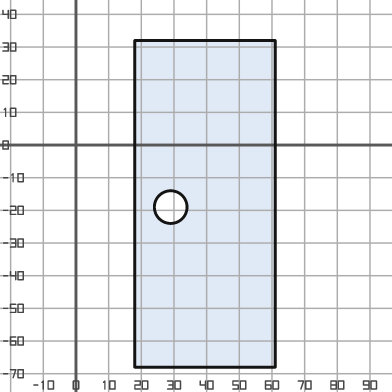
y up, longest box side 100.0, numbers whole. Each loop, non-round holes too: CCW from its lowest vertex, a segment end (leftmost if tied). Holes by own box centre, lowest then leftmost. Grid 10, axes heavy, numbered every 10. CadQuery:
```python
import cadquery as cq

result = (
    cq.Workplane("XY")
    .moveTo(18.0, -68.0)
    .lineTo(61.0, -68.0)
    .lineTo(61.0, 32.0)
    .lineTo(18.0, 32.0)
    .close()
    .moveTo(29.0, -19.0)
    .circle(5.0)
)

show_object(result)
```